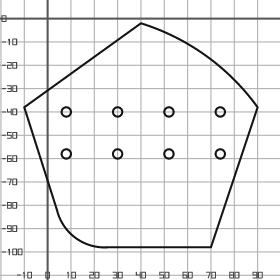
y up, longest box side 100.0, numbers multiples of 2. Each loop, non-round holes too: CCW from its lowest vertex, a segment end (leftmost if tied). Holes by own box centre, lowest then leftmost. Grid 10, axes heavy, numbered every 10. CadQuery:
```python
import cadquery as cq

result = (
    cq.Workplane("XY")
    .moveTo(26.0, -98.0)
    .lineTo(70.0, -98.0)
    .lineTo(90.0, -38.0)
    .threePointArc((68.0, -16.0), (40.0, -2.0))
    .lineTo(-10.0, -38.0)
    .lineTo(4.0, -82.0)
    .threePointArc((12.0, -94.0), (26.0, -98.0))
    .close()
    .moveTo(8.0, -58.0)
    .circle(2.0)
    .moveTo(30.0, -58.0)
    .circle(2.0)
    .moveTo(52.0, -58.0)
    .circle(2.0)
    .moveTo(74.0, -58.0)
    .circle(2.0)
    .moveTo(8.0, -40.0)
    .circle(2.0)
    .moveTo(30.0, -40.0)
    .circle(2.0)
    .moveTo(52.0, -40.0)
    .circle(2.0)
    .moveTo(74.0, -40.0)
    .circle(2.0)
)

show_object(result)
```